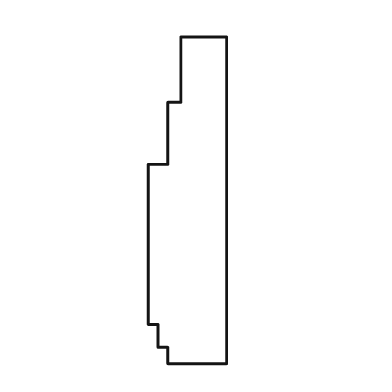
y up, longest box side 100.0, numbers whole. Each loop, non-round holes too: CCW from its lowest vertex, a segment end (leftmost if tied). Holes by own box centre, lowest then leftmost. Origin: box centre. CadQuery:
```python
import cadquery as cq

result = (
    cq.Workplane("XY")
    .moveTo(-6.0, -50.0)
    .lineTo(12.0, -50.0)
    .lineTo(12.0, 50.0)
    .lineTo(-2.0, 50.0)
    .lineTo(-2.0, 30.0)
    .lineTo(-6.0, 30.0)
    .lineTo(-6.0, 11.0)
    .lineTo(-12.0, 11.0)
    .lineTo(-12.0, -38.0)
    .lineTo(-9.0, -38.0)
    .lineTo(-9.0, -45.0)
    .lineTo(-6.0, -45.0)
    .close()
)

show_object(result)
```